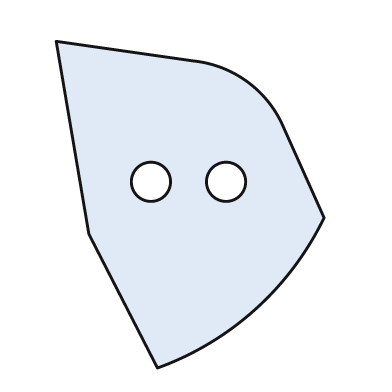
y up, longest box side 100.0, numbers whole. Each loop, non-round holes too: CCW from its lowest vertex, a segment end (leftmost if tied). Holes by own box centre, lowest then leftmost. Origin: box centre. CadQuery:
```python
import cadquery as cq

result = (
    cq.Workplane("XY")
    .moveTo(-10.0, -50.0)
    .threePointArc((20.0, -32.0), (41.0, -4.0))
    .lineTo(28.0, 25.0)
    .threePointArc((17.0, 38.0), (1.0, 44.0))
    .lineTo(-41.0, 50.0)
    .lineTo(-31.0, -9.0)
    .close()
    .moveTo(-12.0, 7.0)
    .circle(6.0)
    .moveTo(11.0, 7.0)
    .circle(6.0)
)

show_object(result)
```